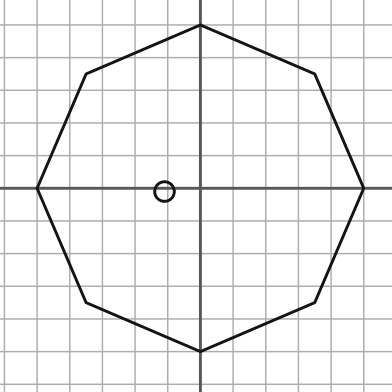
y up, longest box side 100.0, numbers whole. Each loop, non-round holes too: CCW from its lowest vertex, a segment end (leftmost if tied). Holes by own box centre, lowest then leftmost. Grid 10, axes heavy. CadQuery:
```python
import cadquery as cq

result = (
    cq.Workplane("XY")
    .moveTo(0.0, -50.0)
    .lineTo(35.0, -35.0)
    .lineTo(50.0, 0.0)
    .lineTo(35.0, 35.0)
    .lineTo(0.0, 50.0)
    .lineTo(-35.0, 35.0)
    .lineTo(-50.0, 0.0)
    .lineTo(-35.0, -35.0)
    .close()
    .moveTo(-11.0, -1.0)
    .circle(3.0)
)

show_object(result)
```